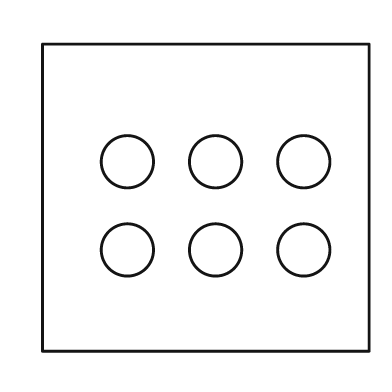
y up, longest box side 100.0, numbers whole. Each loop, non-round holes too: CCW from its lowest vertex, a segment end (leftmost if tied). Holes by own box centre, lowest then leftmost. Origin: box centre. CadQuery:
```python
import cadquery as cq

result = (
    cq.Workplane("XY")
    .moveTo(-50.0, -47.0)
    .lineTo(50.0, -47.0)
    .lineTo(50.0, 47.0)
    .lineTo(-50.0, 47.0)
    .close()
    .moveTo(-24.0, -16.0)
    .circle(8.0)
    .moveTo(3.0, -16.0)
    .circle(8.0)
    .moveTo(30.0, -16.0)
    .circle(8.0)
    .moveTo(-24.0, 11.0)
    .circle(8.0)
    .moveTo(3.0, 11.0)
    .circle(8.0)
    .moveTo(30.0, 11.0)
    .circle(8.0)
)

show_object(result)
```